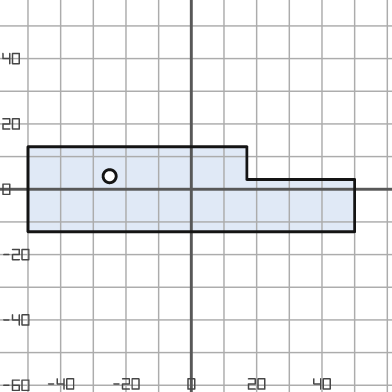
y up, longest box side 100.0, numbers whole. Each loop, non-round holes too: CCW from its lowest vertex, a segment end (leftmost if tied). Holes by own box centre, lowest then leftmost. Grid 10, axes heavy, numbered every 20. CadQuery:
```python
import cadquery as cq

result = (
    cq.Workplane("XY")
    .moveTo(-50.0, -13.0)
    .lineTo(50.0, -13.0)
    .lineTo(50.0, 3.0)
    .lineTo(17.0, 3.0)
    .lineTo(17.0, 13.0)
    .lineTo(-50.0, 13.0)
    .close()
    .moveTo(-25.0, 4.0)
    .circle(2.0)
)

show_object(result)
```